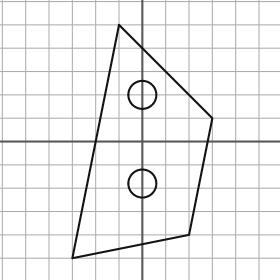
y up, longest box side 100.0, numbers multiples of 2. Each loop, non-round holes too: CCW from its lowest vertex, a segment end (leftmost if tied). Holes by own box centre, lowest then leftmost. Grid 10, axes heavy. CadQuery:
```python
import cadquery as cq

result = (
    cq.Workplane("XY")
    .moveTo(-30.0, -50.0)
    .lineTo(20.0, -40.0)
    .lineTo(30.0, 10.0)
    .lineTo(-10.0, 50.0)
    .close()
    .moveTo(0.0, -18.0)
    .circle(6.0)
    .moveTo(0.0, 20.0)
    .circle(6.0)
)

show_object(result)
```